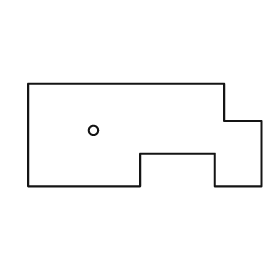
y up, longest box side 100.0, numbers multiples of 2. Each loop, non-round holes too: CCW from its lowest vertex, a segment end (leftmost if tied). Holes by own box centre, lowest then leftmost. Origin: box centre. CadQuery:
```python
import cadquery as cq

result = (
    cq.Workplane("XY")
    .moveTo(-50.0, -22.0)
    .lineTo(-2.0, -22.0)
    .lineTo(-2.0, -8.0)
    .lineTo(30.0, -8.0)
    .lineTo(30.0, -22.0)
    .lineTo(50.0, -22.0)
    .lineTo(50.0, 6.0)
    .lineTo(34.0, 6.0)
    .lineTo(34.0, 22.0)
    .lineTo(-50.0, 22.0)
    .close()
    .moveTo(-22.0, 2.0)
    .circle(2.0)
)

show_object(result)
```